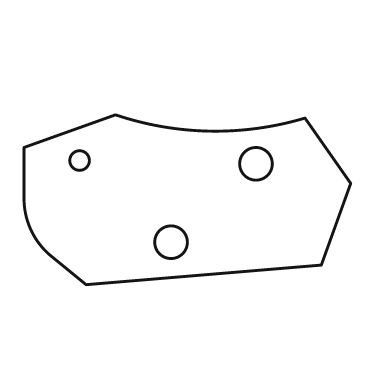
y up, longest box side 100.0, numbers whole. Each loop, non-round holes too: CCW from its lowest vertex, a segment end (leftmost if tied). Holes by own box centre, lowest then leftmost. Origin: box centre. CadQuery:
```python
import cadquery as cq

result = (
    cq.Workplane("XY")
    .moveTo(-31.0, -26.0)
    .lineTo(41.0, -20.0)
    .lineTo(50.0, 5.0)
    .lineTo(36.0, 25.0)
    .threePointArc((7.0, 21.0), (-22.0, 26.0))
    .lineTo(-50.0, 16.0)
    .lineTo(-50.0, 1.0)
    .threePointArc((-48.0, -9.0), (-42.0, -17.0))
    .close()
    .moveTo(-5.0, -13.0)
    .circle(5.0)
    .moveTo(21.0, 11.0)
    .circle(5.0)
    .moveTo(-33.0, 12.0)
    .circle(3.0)
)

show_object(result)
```